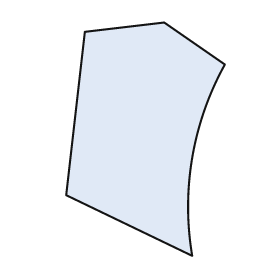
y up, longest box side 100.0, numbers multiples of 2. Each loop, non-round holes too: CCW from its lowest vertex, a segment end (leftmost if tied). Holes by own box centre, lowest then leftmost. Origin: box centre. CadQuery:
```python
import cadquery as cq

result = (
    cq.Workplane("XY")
    .moveTo(20.0, -50.0)
    .threePointArc((20.0, -8.0), (34.0, 32.0))
    .lineTo(8.0, 50.0)
    .lineTo(-26.0, 46.0)
    .lineTo(-34.0, -24.0)
    .close()
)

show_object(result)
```